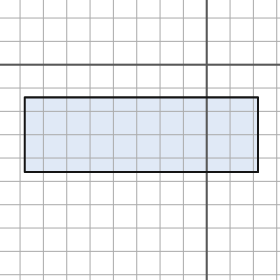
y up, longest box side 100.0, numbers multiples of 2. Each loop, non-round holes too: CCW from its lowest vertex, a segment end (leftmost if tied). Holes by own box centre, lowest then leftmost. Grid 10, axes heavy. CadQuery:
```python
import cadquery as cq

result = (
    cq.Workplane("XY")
    .moveTo(-78.0, -46.0)
    .lineTo(22.0, -46.0)
    .lineTo(22.0, -14.0)
    .lineTo(-78.0, -14.0)
    .close()
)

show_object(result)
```